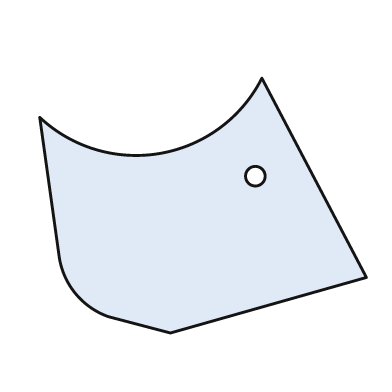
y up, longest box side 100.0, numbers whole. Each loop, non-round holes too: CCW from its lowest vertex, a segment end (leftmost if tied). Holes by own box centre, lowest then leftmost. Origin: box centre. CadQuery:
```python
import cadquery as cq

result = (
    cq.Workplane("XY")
    .moveTo(-10.0, -39.0)
    .lineTo(50.0, -22.0)
    .lineTo(18.0, 39.0)
    .threePointArc((-13.0, 16.0), (-50.0, 27.0))
    .lineTo(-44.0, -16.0)
    .threePointArc((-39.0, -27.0), (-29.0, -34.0))
    .close()
    .moveTo(16.0, 9.0)
    .circle(3.0)
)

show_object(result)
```